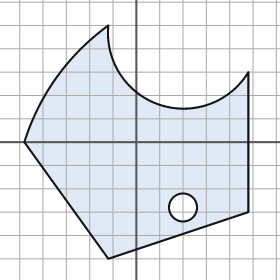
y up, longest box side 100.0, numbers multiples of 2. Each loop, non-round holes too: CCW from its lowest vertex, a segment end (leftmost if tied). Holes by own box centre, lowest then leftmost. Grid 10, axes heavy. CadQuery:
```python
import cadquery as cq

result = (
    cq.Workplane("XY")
    .moveTo(-12.0, -50.0)
    .lineTo(48.0, -30.0)
    .lineTo(48.0, 30.0)
    .threePointArc((10.0, 16.0), (-12.0, 50.0))
    .threePointArc((-34.0, 28.0), (-48.0, 0.0))
    .close()
    .moveTo(20.0, -28.0)
    .circle(6.0)
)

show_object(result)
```